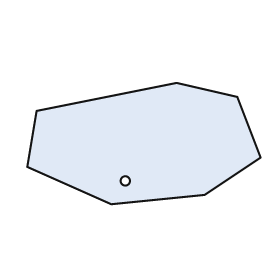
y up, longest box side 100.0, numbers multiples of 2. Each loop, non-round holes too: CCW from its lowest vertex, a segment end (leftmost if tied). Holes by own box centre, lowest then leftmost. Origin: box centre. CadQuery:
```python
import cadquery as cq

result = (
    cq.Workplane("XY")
    .moveTo(-14.0, -26.0)
    .lineTo(26.0, -22.0)
    .lineTo(50.0, -6.0)
    .lineTo(40.0, 20.0)
    .lineTo(14.0, 26.0)
    .lineTo(-46.0, 14.0)
    .lineTo(-50.0, -10.0)
    .close()
    .moveTo(-8.0, -16.0)
    .circle(2.0)
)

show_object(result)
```